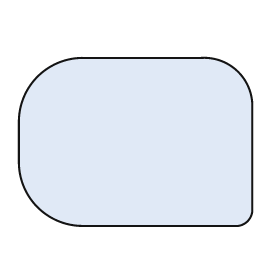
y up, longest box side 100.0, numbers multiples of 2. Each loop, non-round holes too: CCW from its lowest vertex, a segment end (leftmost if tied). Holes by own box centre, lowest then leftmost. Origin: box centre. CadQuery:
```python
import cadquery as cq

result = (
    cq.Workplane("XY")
    .moveTo(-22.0, -36.0)
    .lineTo(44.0, -36.0)
    .threePointArc((48.0, -34.0), (50.0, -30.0))
    .lineTo(50.0, 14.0)
    .threePointArc((44.0, 30.0), (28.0, 36.0))
    .lineTo(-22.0, 36.0)
    .threePointArc((-42.0, 28.0), (-50.0, 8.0))
    .lineTo(-50.0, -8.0)
    .threePointArc((-42.0, -28.0), (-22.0, -36.0))
    .close()
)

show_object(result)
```